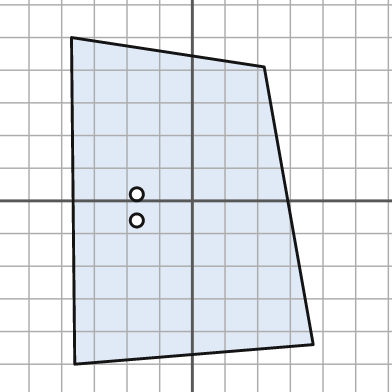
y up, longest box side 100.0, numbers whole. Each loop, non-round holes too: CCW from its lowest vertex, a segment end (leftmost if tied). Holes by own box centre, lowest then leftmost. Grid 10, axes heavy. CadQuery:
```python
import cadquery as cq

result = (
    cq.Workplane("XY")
    .moveTo(-36.0, -50.0)
    .lineTo(37.0, -44.0)
    .lineTo(22.0, 41.0)
    .lineTo(-37.0, 50.0)
    .close()
    .moveTo(-17.0, -6.0)
    .circle(2.0)
    .moveTo(-17.0, 2.0)
    .circle(2.0)
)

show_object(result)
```